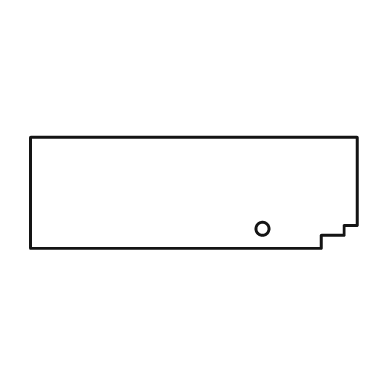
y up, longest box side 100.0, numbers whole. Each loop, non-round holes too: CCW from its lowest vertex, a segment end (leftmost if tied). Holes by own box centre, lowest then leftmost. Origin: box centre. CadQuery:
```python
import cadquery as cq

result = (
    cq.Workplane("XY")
    .moveTo(-50.0, -17.0)
    .lineTo(39.0, -17.0)
    .lineTo(39.0, -13.0)
    .lineTo(46.0, -13.0)
    .lineTo(46.0, -10.0)
    .lineTo(50.0, -10.0)
    .lineTo(50.0, 17.0)
    .lineTo(-50.0, 17.0)
    .close()
    .moveTo(21.0, -11.0)
    .circle(2.0)
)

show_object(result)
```